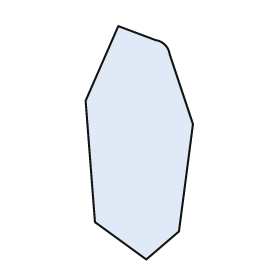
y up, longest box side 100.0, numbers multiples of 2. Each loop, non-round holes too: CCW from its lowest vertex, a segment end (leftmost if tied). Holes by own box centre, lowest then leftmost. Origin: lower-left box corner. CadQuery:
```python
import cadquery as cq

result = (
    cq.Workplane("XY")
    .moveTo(26.0, 0.0)
    .lineTo(40.0, 12.0)
    .lineTo(46.0, 58.0)
    .lineTo(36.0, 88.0)
    .threePointArc((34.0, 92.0), (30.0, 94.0))
    .lineTo(14.0, 100.0)
    .lineTo(0.0, 68.0)
    .lineTo(4.0, 16.0)
    .close()
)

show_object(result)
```